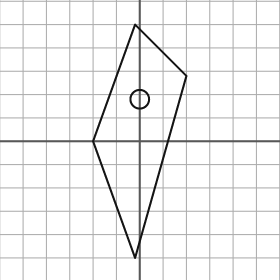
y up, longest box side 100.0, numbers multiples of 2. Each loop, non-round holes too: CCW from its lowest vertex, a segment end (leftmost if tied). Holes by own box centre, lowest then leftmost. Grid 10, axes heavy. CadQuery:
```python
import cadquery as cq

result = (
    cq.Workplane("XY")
    .moveTo(-2.0, -50.0)
    .lineTo(20.0, 28.0)
    .lineTo(-2.0, 50.0)
    .lineTo(-20.0, 0.0)
    .close()
    .moveTo(0.0, 18.0)
    .circle(4.0)
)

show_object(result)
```